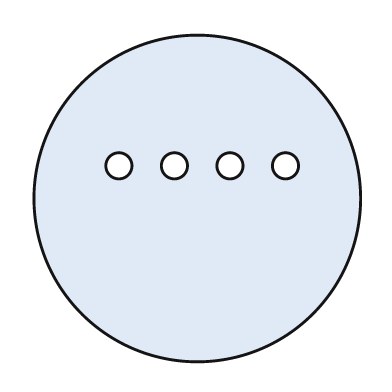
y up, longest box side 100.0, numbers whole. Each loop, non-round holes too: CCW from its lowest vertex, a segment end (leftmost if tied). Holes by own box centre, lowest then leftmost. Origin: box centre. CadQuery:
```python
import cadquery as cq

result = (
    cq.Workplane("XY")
    .moveTo(0.0, 0.0)
    .circle(50.0)
    .moveTo(-24.0, 10.0)
    .circle(4.0)
    .moveTo(-7.0, 10.0)
    .circle(4.0)
    .moveTo(10.0, 10.0)
    .circle(4.0)
    .moveTo(27.0, 10.0)
    .circle(4.0)
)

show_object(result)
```